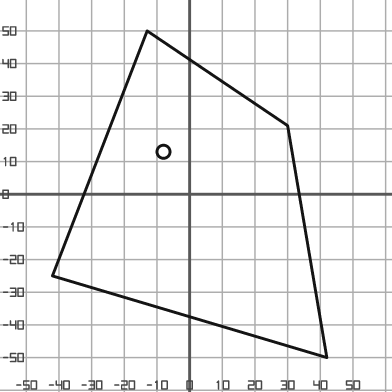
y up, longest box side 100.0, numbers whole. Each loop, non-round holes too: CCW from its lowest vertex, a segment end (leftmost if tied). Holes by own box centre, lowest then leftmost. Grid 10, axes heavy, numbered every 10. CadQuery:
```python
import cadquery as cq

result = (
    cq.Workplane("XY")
    .moveTo(42.0, -50.0)
    .lineTo(30.0, 21.0)
    .lineTo(-13.0, 50.0)
    .lineTo(-42.0, -25.0)
    .close()
    .moveTo(-8.0, 13.0)
    .circle(2.0)
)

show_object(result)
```